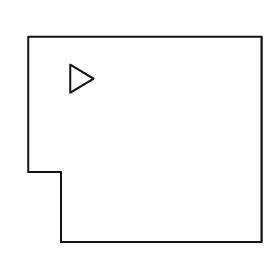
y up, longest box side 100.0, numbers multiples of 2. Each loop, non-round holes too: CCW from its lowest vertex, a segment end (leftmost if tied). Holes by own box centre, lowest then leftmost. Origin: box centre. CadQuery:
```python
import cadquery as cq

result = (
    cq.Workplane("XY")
    .moveTo(-36.0, -44.0)
    .lineTo(50.0, -44.0)
    .lineTo(50.0, 44.0)
    .lineTo(-50.0, 44.0)
    .lineTo(-50.0, -14.0)
    .lineTo(-36.0, -14.0)
    .close()
    .moveTo(-32.0, 20.0)
    .lineTo(-22.0, 26.0)
    .lineTo(-32.0, 32.0)
    .close()
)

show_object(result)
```